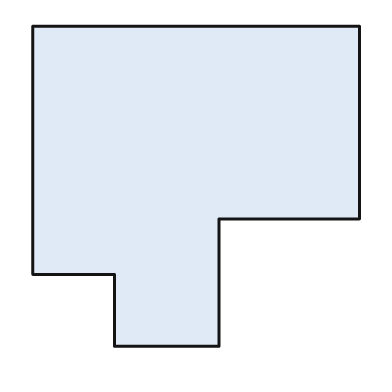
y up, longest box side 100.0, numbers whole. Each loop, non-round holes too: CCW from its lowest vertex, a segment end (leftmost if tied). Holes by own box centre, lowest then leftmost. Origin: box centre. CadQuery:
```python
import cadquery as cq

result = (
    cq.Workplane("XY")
    .moveTo(-25.0, -49.0)
    .lineTo(7.0, -49.0)
    .lineTo(7.0, -10.0)
    .lineTo(50.0, -10.0)
    .lineTo(50.0, 49.0)
    .lineTo(-50.0, 49.0)
    .lineTo(-50.0, -27.0)
    .lineTo(-25.0, -27.0)
    .close()
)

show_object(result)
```